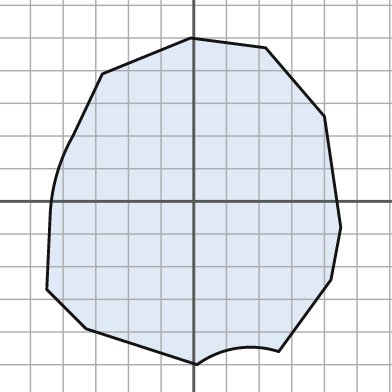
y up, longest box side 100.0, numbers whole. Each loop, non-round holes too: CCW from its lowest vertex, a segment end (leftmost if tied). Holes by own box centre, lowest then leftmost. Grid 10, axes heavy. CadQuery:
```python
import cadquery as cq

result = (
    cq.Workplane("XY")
    .moveTo(1.0, -50.0)
    .threePointArc((13.0, -45.0), (26.0, -46.0))
    .lineTo(42.0, -24.0)
    .lineTo(45.0, -8.0)
    .lineTo(40.0, 26.0)
    .lineTo(22.0, 47.0)
    .lineTo(-1.0, 50.0)
    .lineTo(-28.0, 39.0)
    .lineTo(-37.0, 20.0)
    .threePointArc((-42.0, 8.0), (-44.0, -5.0))
    .lineTo(-45.0, -27.0)
    .lineTo(-33.0, -39.0)
    .close()
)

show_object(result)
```